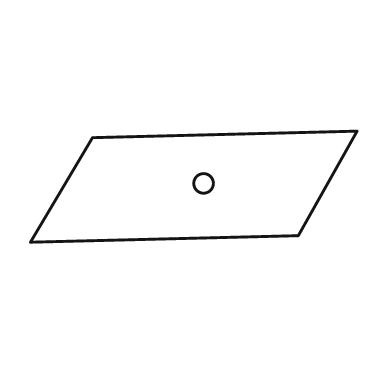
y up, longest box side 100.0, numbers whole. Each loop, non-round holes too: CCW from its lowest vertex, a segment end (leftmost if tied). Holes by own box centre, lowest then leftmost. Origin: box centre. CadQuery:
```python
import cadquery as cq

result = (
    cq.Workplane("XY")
    .moveTo(-50.0, -17.0)
    .lineTo(32.0, -15.0)
    .lineTo(50.0, 17.0)
    .lineTo(-31.0, 15.0)
    .close()
    .moveTo(3.0, 1.0)
    .circle(3.0)
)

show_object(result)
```